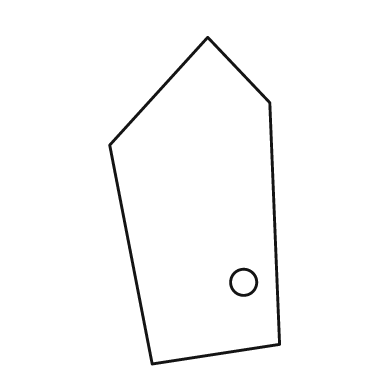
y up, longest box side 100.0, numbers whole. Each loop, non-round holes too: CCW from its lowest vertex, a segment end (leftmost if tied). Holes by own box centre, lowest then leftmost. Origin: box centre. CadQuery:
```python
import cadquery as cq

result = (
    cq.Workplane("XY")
    .moveTo(-13.0, -50.0)
    .lineTo(26.0, -44.0)
    .lineTo(23.0, 30.0)
    .lineTo(4.0, 50.0)
    .lineTo(-26.0, 17.0)
    .close()
    .moveTo(15.0, -25.0)
    .circle(4.0)
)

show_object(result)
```